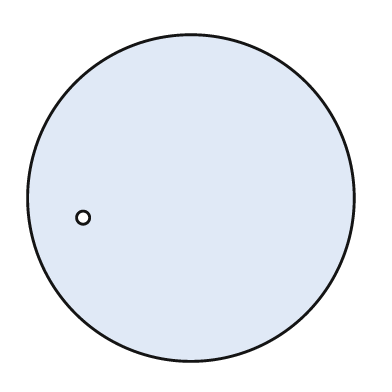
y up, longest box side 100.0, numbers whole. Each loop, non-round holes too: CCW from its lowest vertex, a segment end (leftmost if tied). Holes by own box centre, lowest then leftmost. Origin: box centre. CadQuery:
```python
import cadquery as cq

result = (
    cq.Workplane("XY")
    .moveTo(0.0, 0.0)
    .circle(50.0)
    .moveTo(-33.0, -6.0)
    .circle(2.0)
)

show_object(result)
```